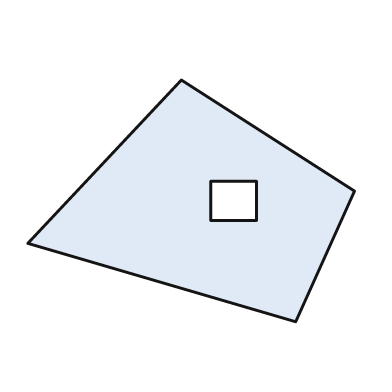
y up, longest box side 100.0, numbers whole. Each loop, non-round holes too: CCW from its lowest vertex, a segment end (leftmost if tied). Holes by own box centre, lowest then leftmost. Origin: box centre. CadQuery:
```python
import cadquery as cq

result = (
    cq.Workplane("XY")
    .moveTo(32.0, -37.0)
    .lineTo(50.0, 3.0)
    .lineTo(-3.0, 37.0)
    .lineTo(-50.0, -13.0)
    .close()
    .moveTo(6.0, -6.0)
    .lineTo(20.0, -6.0)
    .lineTo(20.0, 6.0)
    .lineTo(6.0, 6.0)
    .close()
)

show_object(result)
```